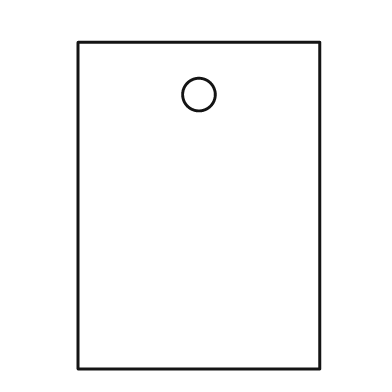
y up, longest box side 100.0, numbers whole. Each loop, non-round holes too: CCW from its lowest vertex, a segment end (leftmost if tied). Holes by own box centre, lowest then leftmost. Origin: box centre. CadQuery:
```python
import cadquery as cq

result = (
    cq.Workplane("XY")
    .moveTo(-37.0, -50.0)
    .lineTo(37.0, -50.0)
    .lineTo(37.0, 50.0)
    .lineTo(-37.0, 50.0)
    .close()
    .moveTo(0.0, 34.0)
    .circle(5.0)
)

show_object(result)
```